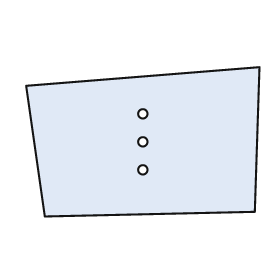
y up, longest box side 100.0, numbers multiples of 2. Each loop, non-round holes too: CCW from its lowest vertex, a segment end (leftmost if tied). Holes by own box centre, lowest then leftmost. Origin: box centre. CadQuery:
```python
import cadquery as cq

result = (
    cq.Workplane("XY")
    .moveTo(-42.0, -32.0)
    .lineTo(48.0, -30.0)
    .lineTo(50.0, 32.0)
    .lineTo(-50.0, 24.0)
    .close()
    .moveTo(0.0, -12.0)
    .circle(2.0)
    .moveTo(0.0, 0.0)
    .circle(2.0)
    .moveTo(0.0, 12.0)
    .circle(2.0)
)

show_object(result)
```